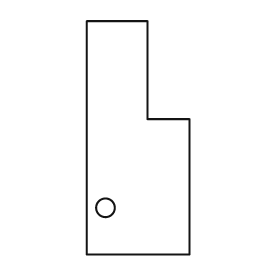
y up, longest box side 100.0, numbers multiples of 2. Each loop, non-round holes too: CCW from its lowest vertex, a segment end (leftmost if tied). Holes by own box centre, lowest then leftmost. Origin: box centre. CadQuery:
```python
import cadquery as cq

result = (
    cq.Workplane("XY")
    .moveTo(-22.0, -50.0)
    .lineTo(22.0, -50.0)
    .lineTo(22.0, 8.0)
    .lineTo(4.0, 8.0)
    .lineTo(4.0, 50.0)
    .lineTo(-22.0, 50.0)
    .close()
    .moveTo(-14.0, -30.0)
    .circle(4.0)
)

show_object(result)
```